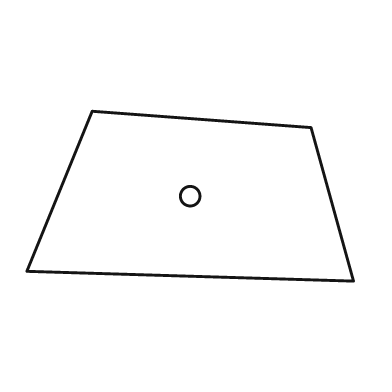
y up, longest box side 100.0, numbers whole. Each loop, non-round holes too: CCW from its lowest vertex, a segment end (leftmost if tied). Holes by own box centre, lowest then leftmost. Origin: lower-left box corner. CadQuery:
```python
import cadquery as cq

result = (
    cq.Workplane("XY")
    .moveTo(100.0, 0.0)
    .lineTo(87.0, 47.0)
    .lineTo(20.0, 52.0)
    .lineTo(0.0, 3.0)
    .close()
    .moveTo(50.0, 26.0)
    .circle(3.0)
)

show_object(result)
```